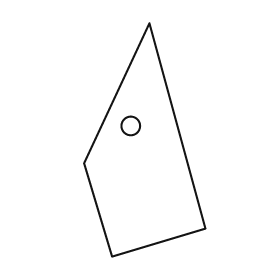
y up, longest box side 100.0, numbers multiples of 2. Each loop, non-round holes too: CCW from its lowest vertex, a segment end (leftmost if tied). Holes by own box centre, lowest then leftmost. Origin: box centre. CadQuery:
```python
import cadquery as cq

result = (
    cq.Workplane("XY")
    .moveTo(-14.0, -50.0)
    .lineTo(26.0, -38.0)
    .lineTo(2.0, 50.0)
    .lineTo(-26.0, -10.0)
    .close()
    .moveTo(-6.0, 6.0)
    .circle(4.0)
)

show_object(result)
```